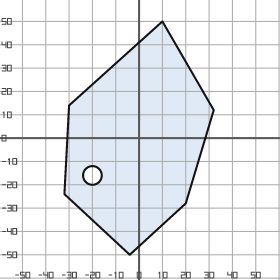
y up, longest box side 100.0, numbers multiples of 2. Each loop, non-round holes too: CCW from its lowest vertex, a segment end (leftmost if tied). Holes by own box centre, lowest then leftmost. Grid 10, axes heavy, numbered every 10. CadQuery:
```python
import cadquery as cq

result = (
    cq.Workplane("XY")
    .moveTo(-4.0, -50.0)
    .lineTo(20.0, -28.0)
    .lineTo(32.0, 12.0)
    .lineTo(10.0, 50.0)
    .lineTo(-30.0, 14.0)
    .lineTo(-32.0, -24.0)
    .close()
    .moveTo(-20.0, -16.0)
    .circle(4.0)
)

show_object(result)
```